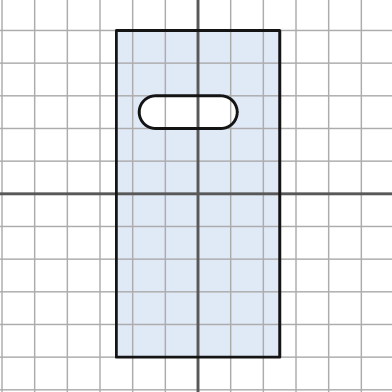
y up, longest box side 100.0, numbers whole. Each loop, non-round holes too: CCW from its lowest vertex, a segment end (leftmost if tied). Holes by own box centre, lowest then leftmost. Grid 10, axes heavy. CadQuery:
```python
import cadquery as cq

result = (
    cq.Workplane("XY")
    .moveTo(-25.0, -50.0)
    .lineTo(25.0, -50.0)
    .lineTo(25.0, 50.0)
    .lineTo(-25.0, 50.0)
    .close()
    .moveTo(-13.0, 20.0)
    .lineTo(7.0, 20.0)
    .threePointArc((12.0, 25.0), (7.0, 30.0))
    .lineTo(-13.0, 30.0)
    .threePointArc((-18.0, 25.0), (-13.0, 20.0))
    .close()
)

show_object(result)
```